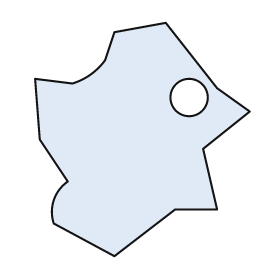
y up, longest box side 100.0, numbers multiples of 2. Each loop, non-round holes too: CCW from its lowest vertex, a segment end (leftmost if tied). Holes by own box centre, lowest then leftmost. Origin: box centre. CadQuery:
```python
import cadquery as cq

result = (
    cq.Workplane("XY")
    .moveTo(-12.0, -50.0)
    .lineTo(14.0, -30.0)
    .lineTo(32.0, -30.0)
    .lineTo(26.0, -4.0)
    .lineTo(46.0, 12.0)
    .lineTo(32.0, 22.0)
    .lineTo(10.0, 50.0)
    .lineTo(-12.0, 46.0)
    .lineTo(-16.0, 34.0)
    .threePointArc((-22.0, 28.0), (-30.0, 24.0))
    .lineTo(-46.0, 26.0)
    .lineTo(-44.0, 0.0)
    .lineTo(-32.0, -18.0)
    .threePointArc((-38.0, -26.0), (-38.0, -36.0))
    .close()
    .moveTo(20.0, 18.0)
    .circle(8.0)
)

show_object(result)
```